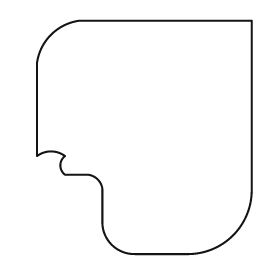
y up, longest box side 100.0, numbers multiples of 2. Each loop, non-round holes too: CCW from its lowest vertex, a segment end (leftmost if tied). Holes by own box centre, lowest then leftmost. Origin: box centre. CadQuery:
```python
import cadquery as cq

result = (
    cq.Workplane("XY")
    .moveTo(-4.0, -50.0)
    .lineTo(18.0, -50.0)
    .threePointArc((38.0, -42.0), (46.0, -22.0))
    .lineTo(46.0, 50.0)
    .lineTo(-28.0, 50.0)
    .threePointArc((-40.0, 44.0), (-46.0, 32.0))
    .lineTo(-46.0, -8.0)
    .threePointArc((-40.0, -6.0), (-34.0, -8.0))
    .threePointArc((-36.0, -12.0), (-34.0, -16.0))
    .lineTo(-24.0, -16.0)
    .threePointArc((-20.0, -18.0), (-18.0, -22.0))
    .lineTo(-18.0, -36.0)
    .threePointArc((-14.0, -46.0), (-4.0, -50.0))
    .close()
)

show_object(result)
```